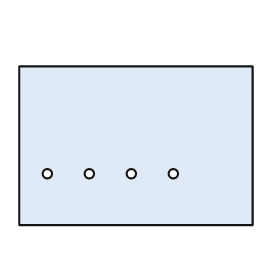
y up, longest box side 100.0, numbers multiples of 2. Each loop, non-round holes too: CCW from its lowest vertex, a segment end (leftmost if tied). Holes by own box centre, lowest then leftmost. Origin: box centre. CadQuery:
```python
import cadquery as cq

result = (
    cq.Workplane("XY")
    .moveTo(-50.0, -34.0)
    .lineTo(50.0, -34.0)
    .lineTo(50.0, 34.0)
    .lineTo(-50.0, 34.0)
    .close()
    .moveTo(-38.0, -12.0)
    .circle(2.0)
    .moveTo(-20.0, -12.0)
    .circle(2.0)
    .moveTo(-2.0, -12.0)
    .circle(2.0)
    .moveTo(16.0, -12.0)
    .circle(2.0)
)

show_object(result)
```